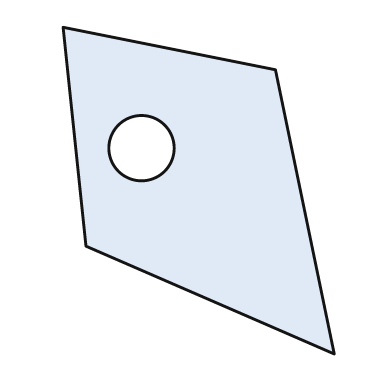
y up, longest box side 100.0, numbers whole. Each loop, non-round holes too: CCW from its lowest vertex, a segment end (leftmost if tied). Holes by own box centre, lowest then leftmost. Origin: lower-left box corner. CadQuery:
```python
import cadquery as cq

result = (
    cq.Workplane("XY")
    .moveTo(83.0, 0.0)
    .lineTo(65.0, 87.0)
    .lineTo(0.0, 100.0)
    .lineTo(7.0, 33.0)
    .close()
    .moveTo(24.0, 63.0)
    .circle(10.0)
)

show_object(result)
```